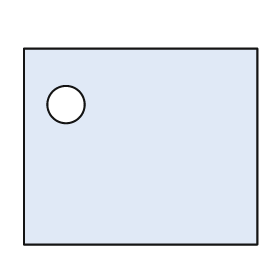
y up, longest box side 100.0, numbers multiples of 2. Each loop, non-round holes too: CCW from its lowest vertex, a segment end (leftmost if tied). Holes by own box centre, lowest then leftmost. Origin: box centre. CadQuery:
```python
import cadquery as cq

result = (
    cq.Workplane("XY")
    .moveTo(-50.0, -42.0)
    .lineTo(50.0, -42.0)
    .lineTo(50.0, 42.0)
    .lineTo(-50.0, 42.0)
    .close()
    .moveTo(-32.0, 18.0)
    .circle(8.0)
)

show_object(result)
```